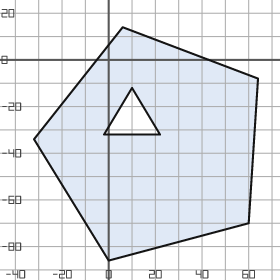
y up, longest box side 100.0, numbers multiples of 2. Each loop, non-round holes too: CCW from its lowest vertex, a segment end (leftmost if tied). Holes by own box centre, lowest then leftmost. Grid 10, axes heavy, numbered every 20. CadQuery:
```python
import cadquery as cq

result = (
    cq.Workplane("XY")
    .moveTo(0.0, -86.0)
    .lineTo(60.0, -70.0)
    .lineTo(64.0, -8.0)
    .lineTo(6.0, 14.0)
    .lineTo(-32.0, -34.0)
    .close()
    .moveTo(-2.0, -32.0)
    .lineTo(22.0, -32.0)
    .lineTo(10.0, -12.0)
    .close()
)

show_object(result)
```